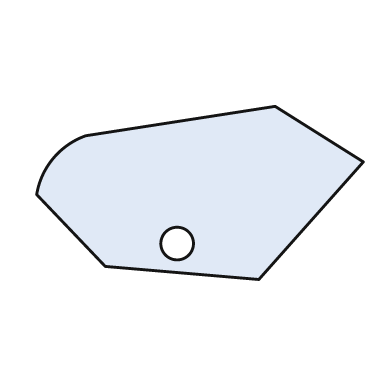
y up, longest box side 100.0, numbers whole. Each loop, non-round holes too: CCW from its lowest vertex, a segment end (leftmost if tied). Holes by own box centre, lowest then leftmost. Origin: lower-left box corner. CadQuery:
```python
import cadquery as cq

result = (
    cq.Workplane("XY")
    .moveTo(68.0, 0.0)
    .lineTo(100.0, 36.0)
    .lineTo(73.0, 53.0)
    .lineTo(15.0, 44.0)
    .threePointArc((5.0, 37.0), (0.0, 26.0))
    .lineTo(21.0, 4.0)
    .close()
    .moveTo(43.0, 11.0)
    .circle(5.0)
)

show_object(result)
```